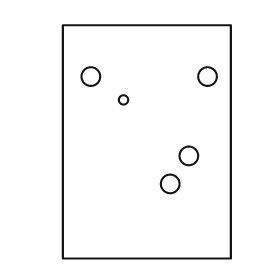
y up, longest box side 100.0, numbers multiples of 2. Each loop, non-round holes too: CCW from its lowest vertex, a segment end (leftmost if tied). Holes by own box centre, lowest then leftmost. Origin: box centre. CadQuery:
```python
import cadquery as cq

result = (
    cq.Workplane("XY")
    .moveTo(-36.0, -50.0)
    .lineTo(36.0, -50.0)
    .lineTo(36.0, 50.0)
    .lineTo(-36.0, 50.0)
    .close()
    .moveTo(10.0, -18.0)
    .circle(4.0)
    .moveTo(18.0, -6.0)
    .circle(4.0)
    .moveTo(-10.0, 18.0)
    .circle(2.0)
    .moveTo(-24.0, 28.0)
    .circle(4.0)
    .moveTo(26.0, 28.0)
    .circle(4.0)
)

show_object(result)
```